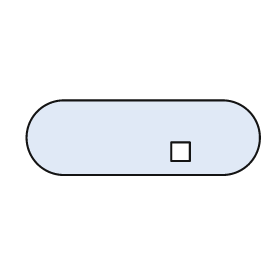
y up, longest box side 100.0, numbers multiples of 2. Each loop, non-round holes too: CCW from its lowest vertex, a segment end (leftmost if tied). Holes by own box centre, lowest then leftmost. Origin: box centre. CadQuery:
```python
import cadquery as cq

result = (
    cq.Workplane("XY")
    .moveTo(-34.0, -16.0)
    .lineTo(34.0, -16.0)
    .threePointArc((50.0, 0.0), (34.0, 16.0))
    .lineTo(-34.0, 16.0)
    .threePointArc((-50.0, 0.0), (-34.0, -16.0))
    .close()
    .moveTo(12.0, -10.0)
    .lineTo(20.0, -10.0)
    .lineTo(20.0, -2.0)
    .lineTo(12.0, -2.0)
    .close()
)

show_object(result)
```